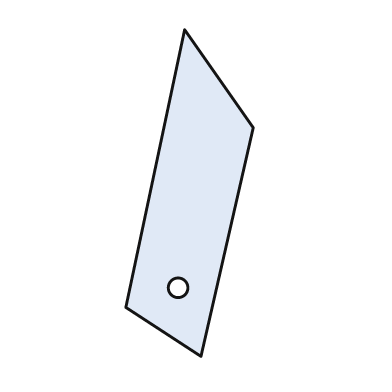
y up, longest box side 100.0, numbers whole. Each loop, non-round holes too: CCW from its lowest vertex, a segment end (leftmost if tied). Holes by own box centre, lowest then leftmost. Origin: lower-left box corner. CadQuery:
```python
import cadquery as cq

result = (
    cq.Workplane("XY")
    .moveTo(23.0, 0.0)
    .lineTo(39.0, 70.0)
    .lineTo(18.0, 100.0)
    .lineTo(0.0, 15.0)
    .close()
    .moveTo(16.0, 21.0)
    .circle(3.0)
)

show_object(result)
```